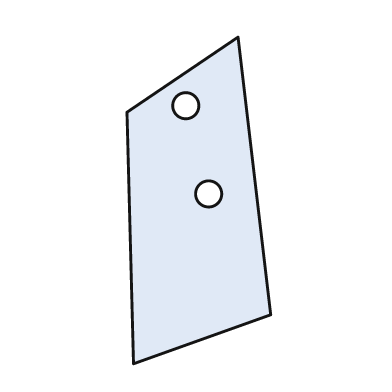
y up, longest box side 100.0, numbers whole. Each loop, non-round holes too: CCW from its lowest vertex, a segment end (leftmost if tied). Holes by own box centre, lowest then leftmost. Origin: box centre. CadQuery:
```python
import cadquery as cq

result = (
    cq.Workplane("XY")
    .moveTo(-20.0, -50.0)
    .lineTo(22.0, -35.0)
    .lineTo(12.0, 50.0)
    .lineTo(-22.0, 27.0)
    .close()
    .moveTo(3.0, 2.0)
    .circle(4.0)
    .moveTo(-4.0, 29.0)
    .circle(4.0)
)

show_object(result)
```